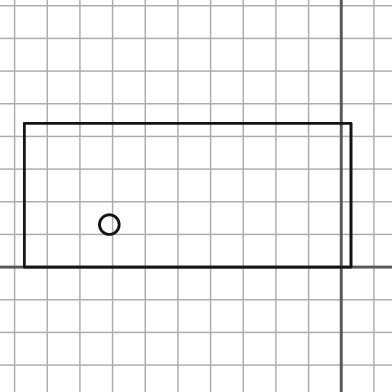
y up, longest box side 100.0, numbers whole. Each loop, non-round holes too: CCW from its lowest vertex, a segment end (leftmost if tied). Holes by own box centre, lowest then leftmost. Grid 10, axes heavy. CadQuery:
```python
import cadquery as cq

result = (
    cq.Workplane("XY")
    .moveTo(-97.0, 0.0)
    .lineTo(3.0, 0.0)
    .lineTo(3.0, 44.0)
    .lineTo(-97.0, 44.0)
    .close()
    .moveTo(-71.0, 13.0)
    .circle(3.0)
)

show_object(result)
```